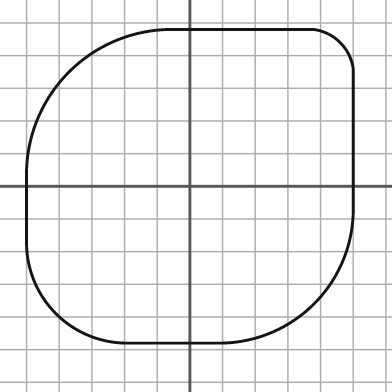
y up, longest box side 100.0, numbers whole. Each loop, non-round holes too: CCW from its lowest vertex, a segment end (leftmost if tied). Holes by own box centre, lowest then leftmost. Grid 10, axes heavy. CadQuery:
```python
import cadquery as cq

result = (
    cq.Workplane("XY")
    .moveTo(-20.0, -48.0)
    .lineTo(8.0, -48.0)
    .threePointArc((38.0, -36.0), (50.0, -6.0))
    .lineTo(50.0, 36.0)
    .threePointArc((46.0, 44.0), (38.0, 48.0))
    .lineTo(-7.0, 48.0)
    .threePointArc((-37.0, 35.0), (-50.0, 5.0))
    .lineTo(-50.0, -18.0)
    .threePointArc((-41.0, -39.0), (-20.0, -48.0))
    .close()
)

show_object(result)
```